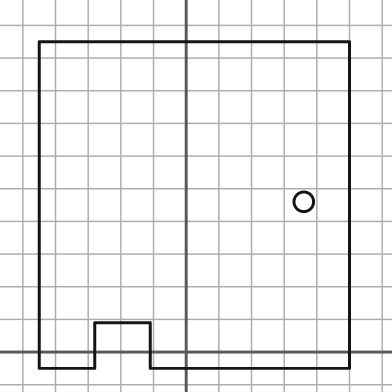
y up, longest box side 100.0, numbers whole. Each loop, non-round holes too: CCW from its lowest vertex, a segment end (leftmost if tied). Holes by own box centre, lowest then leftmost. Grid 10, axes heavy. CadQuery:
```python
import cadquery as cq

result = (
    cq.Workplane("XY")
    .moveTo(-45.0, -5.0)
    .lineTo(-28.0, -5.0)
    .lineTo(-28.0, 9.0)
    .lineTo(-11.0, 9.0)
    .lineTo(-11.0, -5.0)
    .lineTo(50.0, -5.0)
    .lineTo(50.0, 95.0)
    .lineTo(-45.0, 95.0)
    .close()
    .moveTo(36.0, 46.0)
    .circle(3.0)
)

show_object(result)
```